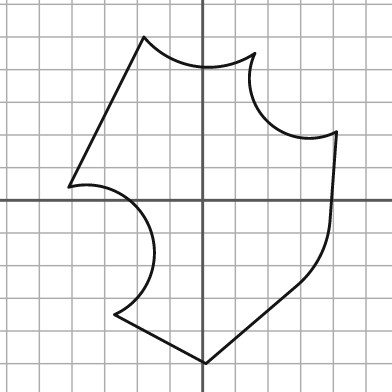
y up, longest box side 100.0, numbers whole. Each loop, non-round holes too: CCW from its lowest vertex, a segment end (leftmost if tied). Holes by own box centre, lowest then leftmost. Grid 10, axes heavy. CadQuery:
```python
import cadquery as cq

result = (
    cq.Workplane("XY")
    .moveTo(1.0, -50.0)
    .lineTo(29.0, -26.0)
    .threePointArc((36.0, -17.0), (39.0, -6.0))
    .lineTo(41.0, 21.0)
    .threePointArc((20.0, 24.0), (16.0, 45.0))
    .threePointArc((-2.0, 41.0), (-18.0, 50.0))
    .lineTo(-41.0, 4.0)
    .threePointArc((-16.0, -9.0), (-27.0, -35.0))
    .close()
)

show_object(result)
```